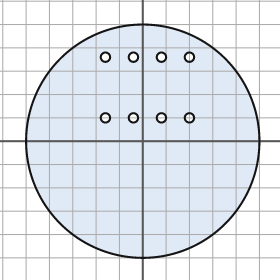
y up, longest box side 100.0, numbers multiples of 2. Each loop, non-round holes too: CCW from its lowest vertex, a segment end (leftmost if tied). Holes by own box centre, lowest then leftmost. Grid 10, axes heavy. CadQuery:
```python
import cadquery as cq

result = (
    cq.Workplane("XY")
    .moveTo(0.0, 0.0)
    .circle(50.0)
    .moveTo(-16.0, 10.0)
    .circle(2.0)
    .moveTo(-4.0, 10.0)
    .circle(2.0)
    .moveTo(8.0, 10.0)
    .circle(2.0)
    .moveTo(20.0, 10.0)
    .circle(2.0)
    .moveTo(-16.0, 36.0)
    .circle(2.0)
    .moveTo(-4.0, 36.0)
    .circle(2.0)
    .moveTo(8.0, 36.0)
    .circle(2.0)
    .moveTo(20.0, 36.0)
    .circle(2.0)
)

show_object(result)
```